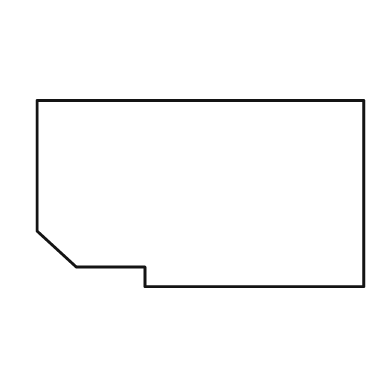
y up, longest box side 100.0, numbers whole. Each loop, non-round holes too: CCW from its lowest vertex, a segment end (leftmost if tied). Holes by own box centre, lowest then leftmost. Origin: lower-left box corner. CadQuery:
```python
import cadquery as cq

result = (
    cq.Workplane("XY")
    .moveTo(33.0, 0.0)
    .lineTo(100.0, 0.0)
    .lineTo(100.0, 57.0)
    .lineTo(0.0, 57.0)
    .lineTo(0.0, 17.0)
    .lineTo(12.0, 6.0)
    .lineTo(33.0, 6.0)
    .close()
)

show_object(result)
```